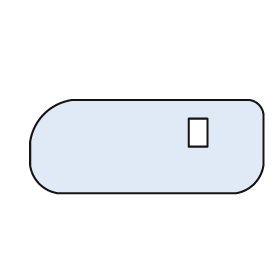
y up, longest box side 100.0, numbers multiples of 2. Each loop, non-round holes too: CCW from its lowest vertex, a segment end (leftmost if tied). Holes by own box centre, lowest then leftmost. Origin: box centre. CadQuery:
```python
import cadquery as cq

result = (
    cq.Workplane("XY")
    .moveTo(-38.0, -20.0)
    .lineTo(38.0, -20.0)
    .threePointArc((46.0, -16.0), (50.0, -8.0))
    .lineTo(50.0, 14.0)
    .threePointArc((48.0, 18.0), (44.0, 20.0))
    .lineTo(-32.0, 20.0)
    .threePointArc((-44.0, 14.0), (-50.0, 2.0))
    .lineTo(-50.0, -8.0)
    .threePointArc((-46.0, -16.0), (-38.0, -20.0))
    .close()
    .moveTo(18.0, 0.0)
    .lineTo(26.0, 0.0)
    .lineTo(26.0, 12.0)
    .lineTo(18.0, 12.0)
    .close()
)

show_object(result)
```